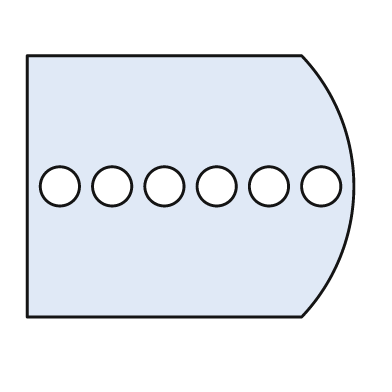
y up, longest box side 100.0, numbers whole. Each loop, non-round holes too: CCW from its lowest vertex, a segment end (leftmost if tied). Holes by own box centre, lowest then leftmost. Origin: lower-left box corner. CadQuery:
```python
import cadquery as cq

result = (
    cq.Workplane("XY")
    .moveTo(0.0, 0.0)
    .lineTo(84.0, 0.0)
    .threePointArc((100.0, 40.0), (84.0, 80.0))
    .lineTo(0.0, 80.0)
    .close()
    .moveTo(10.0, 40.0)
    .circle(6.0)
    .moveTo(26.0, 40.0)
    .circle(6.0)
    .moveTo(42.0, 40.0)
    .circle(6.0)
    .moveTo(58.0, 40.0)
    .circle(6.0)
    .moveTo(74.0, 40.0)
    .circle(6.0)
    .moveTo(90.0, 40.0)
    .circle(6.0)
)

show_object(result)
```